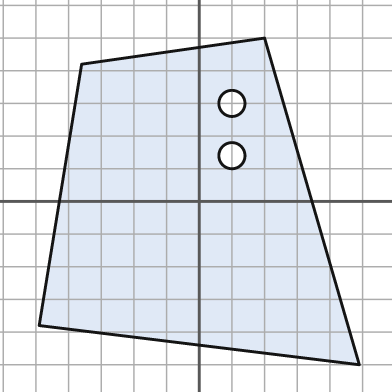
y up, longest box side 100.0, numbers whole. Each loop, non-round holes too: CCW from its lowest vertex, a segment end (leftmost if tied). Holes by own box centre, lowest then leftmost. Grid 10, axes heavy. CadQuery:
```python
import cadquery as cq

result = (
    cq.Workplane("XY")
    .moveTo(49.0, -50.0)
    .lineTo(20.0, 50.0)
    .lineTo(-36.0, 42.0)
    .lineTo(-49.0, -38.0)
    .close()
    .moveTo(10.0, 14.0)
    .circle(4.0)
    .moveTo(10.0, 30.0)
    .circle(4.0)
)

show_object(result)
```